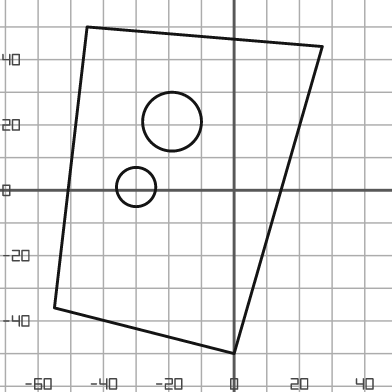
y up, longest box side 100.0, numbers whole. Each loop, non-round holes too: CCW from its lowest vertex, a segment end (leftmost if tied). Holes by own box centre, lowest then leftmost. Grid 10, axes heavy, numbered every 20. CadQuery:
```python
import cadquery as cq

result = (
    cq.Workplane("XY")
    .moveTo(0.0, -50.0)
    .lineTo(27.0, 44.0)
    .lineTo(-45.0, 50.0)
    .lineTo(-55.0, -36.0)
    .close()
    .moveTo(-30.0, 1.0)
    .circle(6.0)
    .moveTo(-19.0, 21.0)
    .circle(9.0)
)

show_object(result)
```